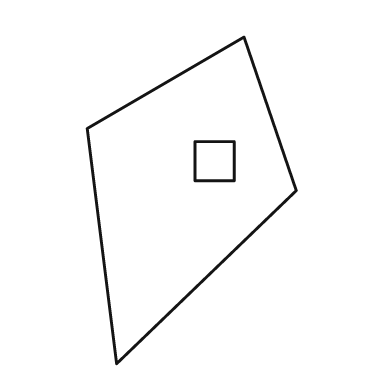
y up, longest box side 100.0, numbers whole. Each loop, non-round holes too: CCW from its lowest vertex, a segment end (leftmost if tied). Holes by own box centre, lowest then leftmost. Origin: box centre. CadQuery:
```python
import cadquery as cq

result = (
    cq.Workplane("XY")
    .moveTo(-23.0, -50.0)
    .lineTo(32.0, 3.0)
    .lineTo(16.0, 50.0)
    .lineTo(-32.0, 22.0)
    .close()
    .moveTo(1.0, 6.0)
    .lineTo(13.0, 6.0)
    .lineTo(13.0, 18.0)
    .lineTo(1.0, 18.0)
    .close()
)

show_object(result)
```